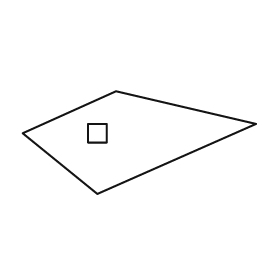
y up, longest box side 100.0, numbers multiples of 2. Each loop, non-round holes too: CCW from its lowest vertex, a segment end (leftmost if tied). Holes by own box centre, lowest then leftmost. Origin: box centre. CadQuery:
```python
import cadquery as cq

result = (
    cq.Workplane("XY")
    .moveTo(-18.0, -22.0)
    .lineTo(50.0, 8.0)
    .lineTo(-10.0, 22.0)
    .lineTo(-50.0, 4.0)
    .close()
    .moveTo(-22.0, 0.0)
    .lineTo(-14.0, 0.0)
    .lineTo(-14.0, 8.0)
    .lineTo(-22.0, 8.0)
    .close()
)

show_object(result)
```